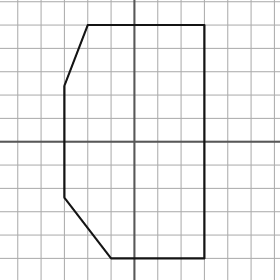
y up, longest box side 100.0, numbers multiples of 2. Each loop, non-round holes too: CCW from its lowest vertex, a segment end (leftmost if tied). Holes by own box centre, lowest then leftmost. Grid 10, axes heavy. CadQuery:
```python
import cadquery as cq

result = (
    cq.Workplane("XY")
    .moveTo(-10.0, -50.0)
    .lineTo(30.0, -50.0)
    .lineTo(30.0, 50.0)
    .lineTo(-20.0, 50.0)
    .lineTo(-30.0, 24.0)
    .lineTo(-30.0, -24.0)
    .close()
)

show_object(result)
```